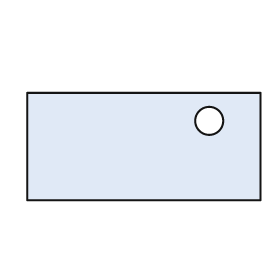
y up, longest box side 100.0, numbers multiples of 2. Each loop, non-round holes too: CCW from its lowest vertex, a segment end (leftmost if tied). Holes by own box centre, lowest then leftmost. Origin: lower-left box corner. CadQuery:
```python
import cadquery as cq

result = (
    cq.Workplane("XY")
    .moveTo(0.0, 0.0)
    .lineTo(100.0, 0.0)
    .lineTo(100.0, 46.0)
    .lineTo(0.0, 46.0)
    .close()
    .moveTo(78.0, 34.0)
    .circle(6.0)
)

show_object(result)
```